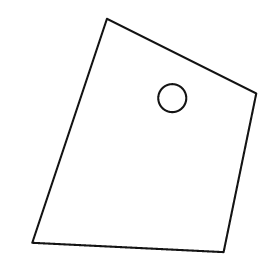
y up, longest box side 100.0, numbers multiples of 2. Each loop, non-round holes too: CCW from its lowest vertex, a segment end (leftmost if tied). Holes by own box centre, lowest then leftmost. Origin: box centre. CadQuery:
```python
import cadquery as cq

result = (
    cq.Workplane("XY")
    .moveTo(34.0, -50.0)
    .lineTo(48.0, 18.0)
    .lineTo(-16.0, 50.0)
    .lineTo(-48.0, -46.0)
    .close()
    .moveTo(12.0, 16.0)
    .circle(6.0)
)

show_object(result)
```